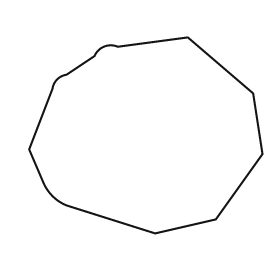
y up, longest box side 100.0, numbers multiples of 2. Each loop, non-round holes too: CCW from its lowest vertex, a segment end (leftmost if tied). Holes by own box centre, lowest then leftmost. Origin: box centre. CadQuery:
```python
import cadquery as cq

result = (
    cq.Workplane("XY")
    .moveTo(4.0, -42.0)
    .lineTo(30.0, -36.0)
    .lineTo(50.0, -8.0)
    .lineTo(46.0, 18.0)
    .lineTo(18.0, 42.0)
    .lineTo(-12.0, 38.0)
    .threePointArc((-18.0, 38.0), (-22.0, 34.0))
    .lineTo(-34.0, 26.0)
    .threePointArc((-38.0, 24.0), (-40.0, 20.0))
    .lineTo(-50.0, -6.0)
    .lineTo(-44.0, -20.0)
    .threePointArc((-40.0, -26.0), (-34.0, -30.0))
    .close()
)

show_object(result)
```